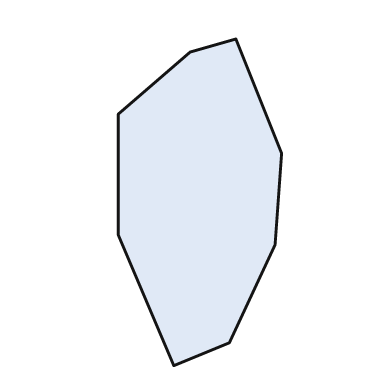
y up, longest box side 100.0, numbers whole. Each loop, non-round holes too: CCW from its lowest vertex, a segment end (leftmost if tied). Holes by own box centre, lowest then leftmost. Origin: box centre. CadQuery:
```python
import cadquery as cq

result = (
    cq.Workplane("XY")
    .moveTo(-8.0, -50.0)
    .lineTo(9.0, -43.0)
    .lineTo(23.0, -13.0)
    .lineTo(25.0, 15.0)
    .lineTo(11.0, 50.0)
    .lineTo(-3.0, 46.0)
    .lineTo(-25.0, 27.0)
    .lineTo(-25.0, -10.0)
    .close()
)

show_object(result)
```